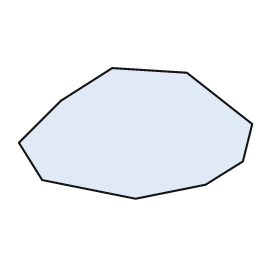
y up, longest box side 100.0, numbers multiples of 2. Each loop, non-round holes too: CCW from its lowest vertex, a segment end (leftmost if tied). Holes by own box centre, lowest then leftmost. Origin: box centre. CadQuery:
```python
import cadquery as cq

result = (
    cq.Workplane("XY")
    .moveTo(0.0, -28.0)
    .lineTo(30.0, -22.0)
    .lineTo(46.0, -12.0)
    .lineTo(50.0, 4.0)
    .lineTo(22.0, 26.0)
    .lineTo(-10.0, 28.0)
    .lineTo(-32.0, 14.0)
    .lineTo(-50.0, -4.0)
    .lineTo(-40.0, -20.0)
    .close()
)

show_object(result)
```